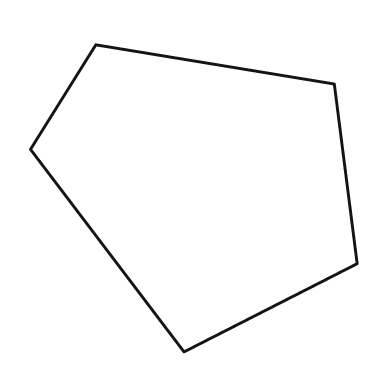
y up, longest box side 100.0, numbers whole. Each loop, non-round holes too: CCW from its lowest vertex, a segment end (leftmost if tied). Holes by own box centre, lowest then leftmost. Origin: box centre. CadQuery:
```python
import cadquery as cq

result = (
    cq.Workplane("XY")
    .moveTo(-3.0, -47.0)
    .lineTo(50.0, -20.0)
    .lineTo(43.0, 35.0)
    .lineTo(-30.0, 47.0)
    .lineTo(-50.0, 15.0)
    .close()
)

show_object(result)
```